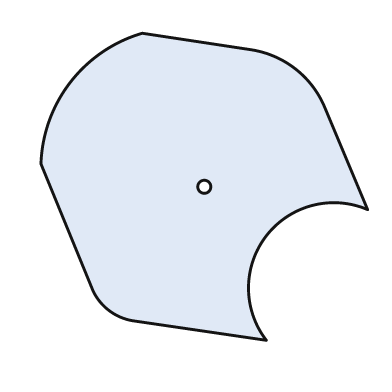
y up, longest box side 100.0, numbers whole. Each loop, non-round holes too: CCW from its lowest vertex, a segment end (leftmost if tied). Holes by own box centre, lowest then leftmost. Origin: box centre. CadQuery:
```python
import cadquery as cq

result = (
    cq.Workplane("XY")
    .moveTo(19.0, -47.0)
    .threePointArc((19.0, -15.0), (50.0, -7.0))
    .lineTo(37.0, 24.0)
    .threePointArc((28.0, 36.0), (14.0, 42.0))
    .lineTo(-19.0, 47.0)
    .threePointArc((-41.0, 32.0), (-50.0, 7.0))
    .lineTo(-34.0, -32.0)
    .threePointArc((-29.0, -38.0), (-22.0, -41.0))
    .close()
    .moveTo(0.0, 0.0)
    .circle(2.0)
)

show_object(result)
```